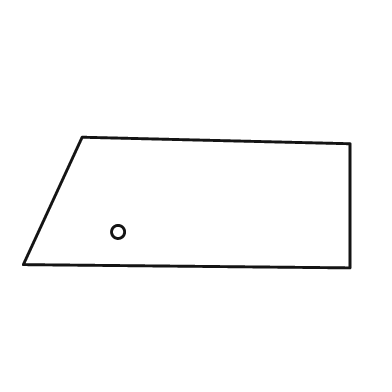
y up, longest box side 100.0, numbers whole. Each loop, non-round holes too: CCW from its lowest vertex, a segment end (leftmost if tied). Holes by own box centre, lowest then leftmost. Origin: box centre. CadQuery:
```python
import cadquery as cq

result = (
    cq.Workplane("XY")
    .moveTo(50.0, -20.0)
    .lineTo(50.0, 18.0)
    .lineTo(-32.0, 20.0)
    .lineTo(-50.0, -19.0)
    .close()
    .moveTo(-21.0, -9.0)
    .circle(2.0)
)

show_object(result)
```